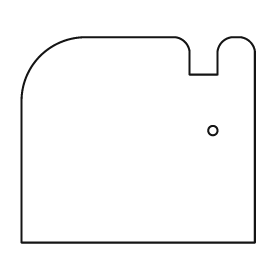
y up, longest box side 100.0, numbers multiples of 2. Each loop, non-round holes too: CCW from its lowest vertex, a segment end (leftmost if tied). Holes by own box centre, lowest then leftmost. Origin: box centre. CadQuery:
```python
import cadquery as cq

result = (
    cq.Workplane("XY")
    .moveTo(-50.0, -44.0)
    .lineTo(50.0, -44.0)
    .lineTo(50.0, 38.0)
    .threePointArc((48.0, 42.0), (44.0, 44.0))
    .lineTo(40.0, 44.0)
    .threePointArc((36.0, 42.0), (34.0, 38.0))
    .lineTo(34.0, 28.0)
    .lineTo(22.0, 28.0)
    .lineTo(22.0, 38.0)
    .threePointArc((20.0, 42.0), (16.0, 44.0))
    .lineTo(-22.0, 44.0)
    .threePointArc((-42.0, 36.0), (-50.0, 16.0))
    .close()
    .moveTo(32.0, 4.0)
    .circle(2.0)
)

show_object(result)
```